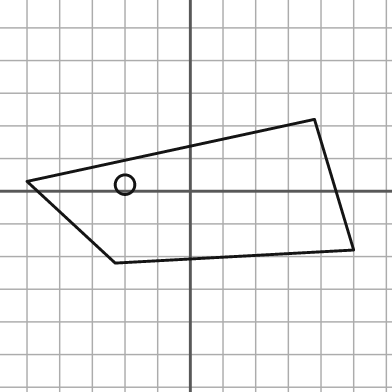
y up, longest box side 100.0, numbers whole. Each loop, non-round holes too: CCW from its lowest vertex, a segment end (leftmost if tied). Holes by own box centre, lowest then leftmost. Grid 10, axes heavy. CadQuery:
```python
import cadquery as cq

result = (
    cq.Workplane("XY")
    .moveTo(-23.0, -22.0)
    .lineTo(50.0, -18.0)
    .lineTo(38.0, 22.0)
    .lineTo(-50.0, 3.0)
    .close()
    .moveTo(-20.0, 2.0)
    .circle(3.0)
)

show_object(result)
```